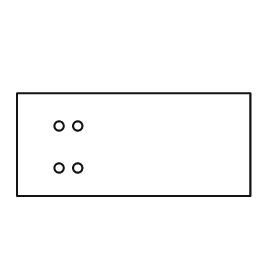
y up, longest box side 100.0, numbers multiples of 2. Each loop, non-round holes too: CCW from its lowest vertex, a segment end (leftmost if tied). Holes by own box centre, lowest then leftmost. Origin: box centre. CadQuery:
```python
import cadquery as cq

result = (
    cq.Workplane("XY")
    .moveTo(-50.0, -22.0)
    .lineTo(50.0, -22.0)
    .lineTo(50.0, 22.0)
    .lineTo(-50.0, 22.0)
    .close()
    .moveTo(-32.0, -10.0)
    .circle(2.0)
    .moveTo(-24.0, -10.0)
    .circle(2.0)
    .moveTo(-32.0, 8.0)
    .circle(2.0)
    .moveTo(-24.0, 8.0)
    .circle(2.0)
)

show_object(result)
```